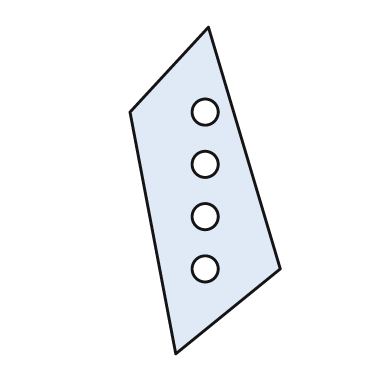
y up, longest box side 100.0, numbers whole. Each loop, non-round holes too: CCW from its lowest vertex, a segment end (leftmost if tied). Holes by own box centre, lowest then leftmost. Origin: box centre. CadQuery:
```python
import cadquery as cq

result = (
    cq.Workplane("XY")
    .moveTo(-9.0, -50.0)
    .lineTo(23.0, -24.0)
    .lineTo(1.0, 50.0)
    .lineTo(-23.0, 24.0)
    .close()
    .moveTo(0.0, -24.0)
    .circle(4.0)
    .moveTo(0.0, -8.0)
    .circle(4.0)
    .moveTo(0.0, 8.0)
    .circle(4.0)
    .moveTo(0.0, 24.0)
    .circle(4.0)
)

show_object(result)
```